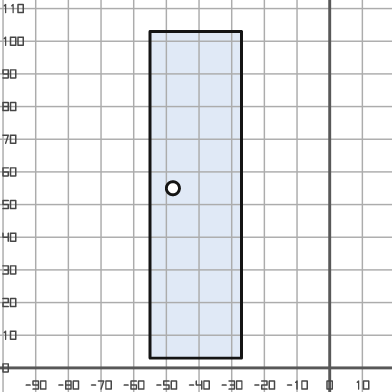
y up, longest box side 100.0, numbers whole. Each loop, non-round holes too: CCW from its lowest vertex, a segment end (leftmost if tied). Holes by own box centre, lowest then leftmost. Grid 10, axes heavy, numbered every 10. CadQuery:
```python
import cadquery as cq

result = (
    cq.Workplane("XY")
    .moveTo(-55.0, 3.0)
    .lineTo(-27.0, 3.0)
    .lineTo(-27.0, 103.0)
    .lineTo(-55.0, 103.0)
    .close()
    .moveTo(-48.0, 55.0)
    .circle(2.0)
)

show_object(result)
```